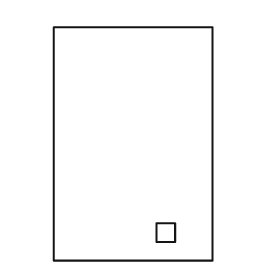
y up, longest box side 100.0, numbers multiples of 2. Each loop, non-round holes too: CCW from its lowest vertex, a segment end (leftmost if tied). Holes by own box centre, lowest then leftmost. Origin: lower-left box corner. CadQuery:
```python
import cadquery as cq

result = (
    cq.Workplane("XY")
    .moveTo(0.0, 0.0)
    .lineTo(68.0, 0.0)
    .lineTo(68.0, 100.0)
    .lineTo(0.0, 100.0)
    .close()
    .moveTo(44.0, 8.0)
    .lineTo(52.0, 8.0)
    .lineTo(52.0, 16.0)
    .lineTo(44.0, 16.0)
    .close()
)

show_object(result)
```